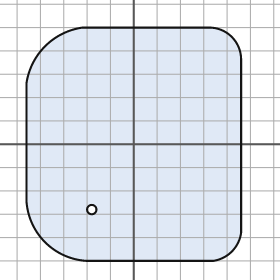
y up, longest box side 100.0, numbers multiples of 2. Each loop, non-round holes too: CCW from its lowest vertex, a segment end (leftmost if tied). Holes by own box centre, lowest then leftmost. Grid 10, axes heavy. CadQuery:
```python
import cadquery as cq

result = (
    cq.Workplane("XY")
    .moveTo(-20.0, -50.0)
    .lineTo(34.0, -50.0)
    .threePointArc((42.0, -46.0), (46.0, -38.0))
    .lineTo(46.0, 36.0)
    .threePointArc((42.0, 46.0), (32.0, 50.0))
    .lineTo(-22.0, 50.0)
    .threePointArc((-38.0, 42.0), (-46.0, 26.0))
    .lineTo(-46.0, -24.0)
    .threePointArc((-38.0, -42.0), (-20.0, -50.0))
    .close()
    .moveTo(-18.0, -28.0)
    .circle(2.0)
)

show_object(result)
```